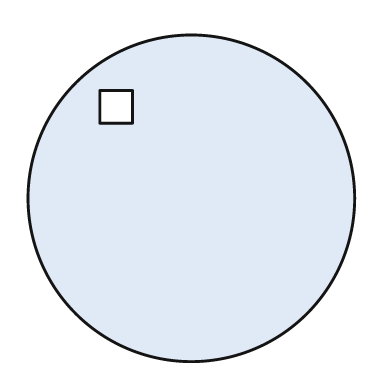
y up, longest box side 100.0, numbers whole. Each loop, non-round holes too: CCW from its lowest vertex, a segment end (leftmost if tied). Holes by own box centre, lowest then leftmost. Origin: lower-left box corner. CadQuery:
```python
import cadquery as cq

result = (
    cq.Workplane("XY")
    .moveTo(50.0, 50.0)
    .circle(50.0)
    .moveTo(22.0, 73.0)
    .lineTo(32.0, 73.0)
    .lineTo(32.0, 83.0)
    .lineTo(22.0, 83.0)
    .close()
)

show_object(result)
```